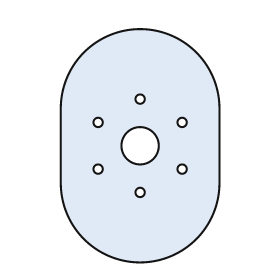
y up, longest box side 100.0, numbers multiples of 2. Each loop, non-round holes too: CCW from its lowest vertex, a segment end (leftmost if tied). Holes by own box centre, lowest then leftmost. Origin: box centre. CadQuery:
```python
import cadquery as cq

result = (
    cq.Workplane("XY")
    .moveTo(-34.0, -16.0)
    .threePointArc((0.0, -50.0), (34.0, -16.0))
    .lineTo(34.0, 16.0)
    .threePointArc((0.0, 50.0), (-34.0, 16.0))
    .close()
    .moveTo(0.0, -20.0)
    .circle(2.0)
    .moveTo(-18.0, -10.0)
    .circle(2.0)
    .moveTo(18.0, -10.0)
    .circle(2.0)
    .moveTo(0.0, 0.0)
    .circle(8.0)
    .moveTo(-18.0, 10.0)
    .circle(2.0)
    .moveTo(18.0, 10.0)
    .circle(2.0)
    .moveTo(0.0, 20.0)
    .circle(2.0)
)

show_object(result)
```